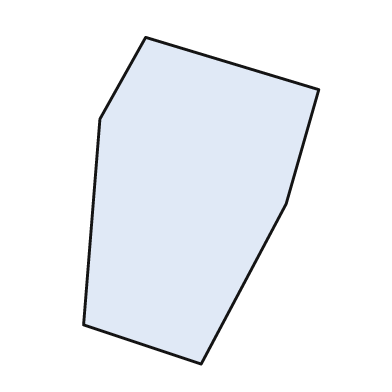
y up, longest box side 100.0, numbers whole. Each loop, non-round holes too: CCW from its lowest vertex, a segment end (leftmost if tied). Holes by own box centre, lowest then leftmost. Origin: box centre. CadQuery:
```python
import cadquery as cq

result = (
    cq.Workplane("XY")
    .moveTo(0.0, -50.0)
    .lineTo(26.0, -1.0)
    .lineTo(36.0, 34.0)
    .lineTo(-17.0, 50.0)
    .lineTo(-31.0, 25.0)
    .lineTo(-36.0, -38.0)
    .close()
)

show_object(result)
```